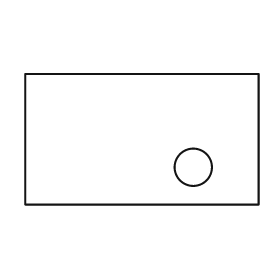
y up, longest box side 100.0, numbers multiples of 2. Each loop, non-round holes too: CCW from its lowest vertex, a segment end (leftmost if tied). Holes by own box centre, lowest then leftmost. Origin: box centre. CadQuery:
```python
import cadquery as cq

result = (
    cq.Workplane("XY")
    .moveTo(-50.0, -28.0)
    .lineTo(50.0, -28.0)
    .lineTo(50.0, 28.0)
    .lineTo(-50.0, 28.0)
    .close()
    .moveTo(22.0, -12.0)
    .circle(8.0)
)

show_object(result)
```